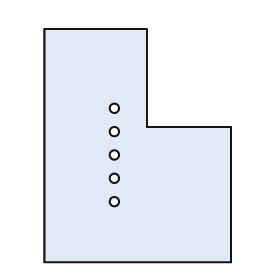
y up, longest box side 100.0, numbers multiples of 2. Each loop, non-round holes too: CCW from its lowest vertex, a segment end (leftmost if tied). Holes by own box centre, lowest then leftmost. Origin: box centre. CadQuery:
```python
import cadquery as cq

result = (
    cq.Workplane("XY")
    .moveTo(-40.0, -50.0)
    .lineTo(40.0, -50.0)
    .lineTo(40.0, 8.0)
    .lineTo(4.0, 8.0)
    .lineTo(4.0, 50.0)
    .lineTo(-40.0, 50.0)
    .close()
    .moveTo(-10.0, -24.0)
    .circle(2.0)
    .moveTo(-10.0, -14.0)
    .circle(2.0)
    .moveTo(-10.0, -4.0)
    .circle(2.0)
    .moveTo(-10.0, 6.0)
    .circle(2.0)
    .moveTo(-10.0, 16.0)
    .circle(2.0)
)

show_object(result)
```